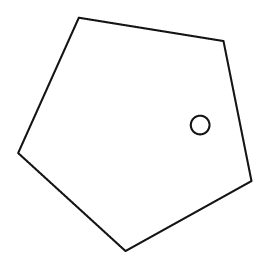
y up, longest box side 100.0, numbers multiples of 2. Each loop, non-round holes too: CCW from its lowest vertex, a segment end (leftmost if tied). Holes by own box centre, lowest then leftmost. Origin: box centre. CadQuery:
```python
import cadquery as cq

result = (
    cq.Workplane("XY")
    .moveTo(-4.0, -50.0)
    .lineTo(50.0, -20.0)
    .lineTo(38.0, 40.0)
    .lineTo(-24.0, 50.0)
    .lineTo(-50.0, -8.0)
    .close()
    .moveTo(28.0, 4.0)
    .circle(4.0)
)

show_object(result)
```